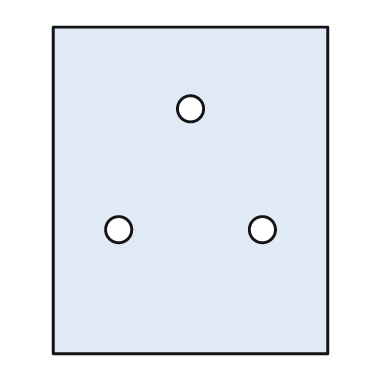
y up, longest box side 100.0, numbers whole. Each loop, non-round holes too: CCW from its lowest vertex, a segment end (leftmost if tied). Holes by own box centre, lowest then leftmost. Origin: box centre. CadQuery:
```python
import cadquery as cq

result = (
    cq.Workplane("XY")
    .moveTo(-42.0, -50.0)
    .lineTo(42.0, -50.0)
    .lineTo(42.0, 50.0)
    .lineTo(-42.0, 50.0)
    .close()
    .moveTo(-22.0, -12.0)
    .circle(4.0)
    .moveTo(22.0, -12.0)
    .circle(4.0)
    .moveTo(0.0, 25.0)
    .circle(4.0)
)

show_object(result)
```